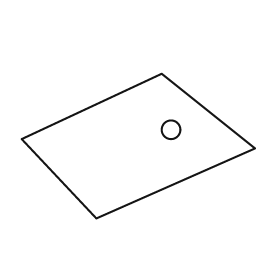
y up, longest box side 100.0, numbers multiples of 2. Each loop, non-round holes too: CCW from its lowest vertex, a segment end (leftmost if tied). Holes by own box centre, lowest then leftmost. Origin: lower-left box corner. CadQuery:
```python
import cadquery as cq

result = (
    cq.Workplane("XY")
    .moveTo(32.0, 0.0)
    .lineTo(100.0, 30.0)
    .lineTo(60.0, 62.0)
    .lineTo(0.0, 34.0)
    .close()
    .moveTo(64.0, 38.0)
    .circle(4.0)
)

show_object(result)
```